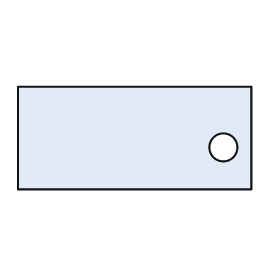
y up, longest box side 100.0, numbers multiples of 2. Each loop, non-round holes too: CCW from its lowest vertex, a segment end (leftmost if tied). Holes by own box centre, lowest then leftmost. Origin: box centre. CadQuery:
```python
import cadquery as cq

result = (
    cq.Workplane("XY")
    .moveTo(-50.0, -22.0)
    .lineTo(50.0, -22.0)
    .lineTo(50.0, 22.0)
    .lineTo(-50.0, 22.0)
    .close()
    .moveTo(38.0, -4.0)
    .circle(6.0)
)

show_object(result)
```